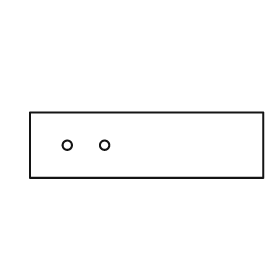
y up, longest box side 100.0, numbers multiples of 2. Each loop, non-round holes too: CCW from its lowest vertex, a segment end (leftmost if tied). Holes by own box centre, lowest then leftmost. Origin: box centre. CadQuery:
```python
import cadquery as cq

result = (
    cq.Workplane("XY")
    .moveTo(-50.0, -14.0)
    .lineTo(50.0, -14.0)
    .lineTo(50.0, 14.0)
    .lineTo(-50.0, 14.0)
    .close()
    .moveTo(-34.0, 0.0)
    .circle(2.0)
    .moveTo(-18.0, 0.0)
    .circle(2.0)
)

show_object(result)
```